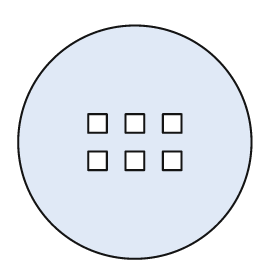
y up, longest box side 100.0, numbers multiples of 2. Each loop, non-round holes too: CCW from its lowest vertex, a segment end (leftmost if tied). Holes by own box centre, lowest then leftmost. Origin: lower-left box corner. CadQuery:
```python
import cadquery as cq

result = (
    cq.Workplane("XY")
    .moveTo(50.0, 50.0)
    .circle(50.0)
    .moveTo(30.0, 38.0)
    .lineTo(38.0, 38.0)
    .lineTo(38.0, 46.0)
    .lineTo(30.0, 46.0)
    .close()
    .moveTo(46.0, 38.0)
    .lineTo(54.0, 38.0)
    .lineTo(54.0, 46.0)
    .lineTo(46.0, 46.0)
    .close()
    .moveTo(62.0, 38.0)
    .lineTo(70.0, 38.0)
    .lineTo(70.0, 46.0)
    .lineTo(62.0, 46.0)
    .close()
    .moveTo(30.0, 54.0)
    .lineTo(38.0, 54.0)
    .lineTo(38.0, 62.0)
    .lineTo(30.0, 62.0)
    .close()
    .moveTo(46.0, 54.0)
    .lineTo(54.0, 54.0)
    .lineTo(54.0, 62.0)
    .lineTo(46.0, 62.0)
    .close()
    .moveTo(62.0, 54.0)
    .lineTo(70.0, 54.0)
    .lineTo(70.0, 62.0)
    .lineTo(62.0, 62.0)
    .close()
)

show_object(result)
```